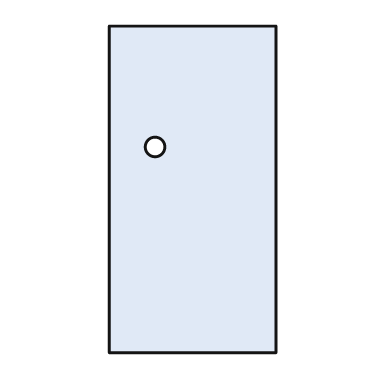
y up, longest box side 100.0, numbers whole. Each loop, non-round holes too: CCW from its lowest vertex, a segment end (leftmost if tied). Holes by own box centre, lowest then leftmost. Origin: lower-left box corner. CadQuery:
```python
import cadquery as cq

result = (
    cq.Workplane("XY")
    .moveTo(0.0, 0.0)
    .lineTo(51.0, 0.0)
    .lineTo(51.0, 100.0)
    .lineTo(0.0, 100.0)
    .close()
    .moveTo(14.0, 63.0)
    .circle(3.0)
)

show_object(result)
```